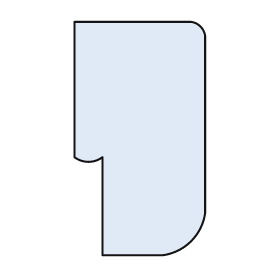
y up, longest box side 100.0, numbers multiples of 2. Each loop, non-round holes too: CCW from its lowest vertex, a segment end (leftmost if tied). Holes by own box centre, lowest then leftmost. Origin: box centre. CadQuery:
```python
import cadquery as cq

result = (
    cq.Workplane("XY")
    .moveTo(-16.0, -50.0)
    .lineTo(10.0, -50.0)
    .threePointArc((22.0, -44.0), (28.0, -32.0))
    .lineTo(28.0, 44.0)
    .threePointArc((26.0, 48.0), (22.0, 50.0))
    .lineTo(-28.0, 50.0)
    .lineTo(-28.0, -8.0)
    .threePointArc((-22.0, -10.0), (-16.0, -8.0))
    .close()
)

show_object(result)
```